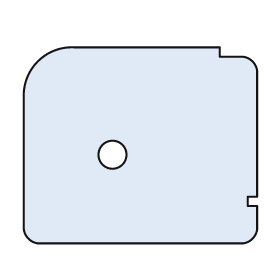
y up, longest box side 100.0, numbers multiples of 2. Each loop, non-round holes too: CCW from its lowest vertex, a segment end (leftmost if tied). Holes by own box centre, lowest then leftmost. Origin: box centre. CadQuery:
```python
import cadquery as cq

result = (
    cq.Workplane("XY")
    .moveTo(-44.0, -42.0)
    .lineTo(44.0, -42.0)
    .threePointArc((48.0, -40.0), (50.0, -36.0))
    .lineTo(50.0, -26.0)
    .lineTo(46.0, -26.0)
    .lineTo(46.0, -22.0)
    .lineTo(50.0, -22.0)
    .lineTo(50.0, 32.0)
    .threePointArc((48.0, 36.0), (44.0, 38.0))
    .lineTo(34.0, 38.0)
    .lineTo(34.0, 42.0)
    .lineTo(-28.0, 42.0)
    .threePointArc((-44.0, 36.0), (-50.0, 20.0))
    .lineTo(-50.0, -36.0)
    .threePointArc((-48.0, -40.0), (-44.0, -42.0))
    .close()
    .moveTo(-12.0, -4.0)
    .circle(6.0)
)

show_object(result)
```